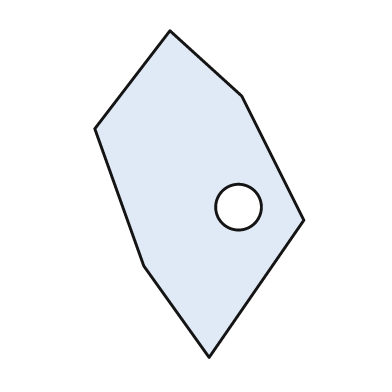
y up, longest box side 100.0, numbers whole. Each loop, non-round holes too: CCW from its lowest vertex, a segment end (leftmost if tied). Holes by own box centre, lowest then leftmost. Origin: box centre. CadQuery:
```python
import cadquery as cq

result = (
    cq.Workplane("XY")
    .moveTo(3.0, -50.0)
    .lineTo(32.0, -8.0)
    .lineTo(13.0, 30.0)
    .lineTo(-9.0, 50.0)
    .lineTo(-32.0, 20.0)
    .lineTo(-17.0, -22.0)
    .close()
    .moveTo(12.0, -4.0)
    .circle(7.0)
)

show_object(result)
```